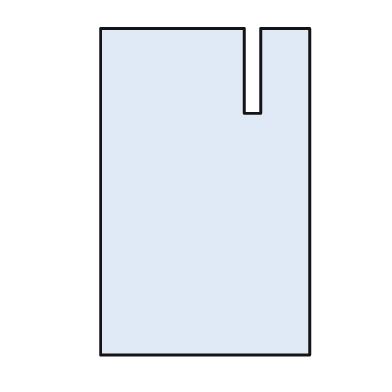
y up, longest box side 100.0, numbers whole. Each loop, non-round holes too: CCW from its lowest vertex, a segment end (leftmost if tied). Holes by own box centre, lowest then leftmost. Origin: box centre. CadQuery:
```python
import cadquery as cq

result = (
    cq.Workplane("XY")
    .moveTo(-32.0, -50.0)
    .lineTo(32.0, -50.0)
    .lineTo(32.0, 50.0)
    .lineTo(17.0, 50.0)
    .lineTo(17.0, 24.0)
    .lineTo(12.0, 24.0)
    .lineTo(12.0, 50.0)
    .lineTo(-32.0, 50.0)
    .close()
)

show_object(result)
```